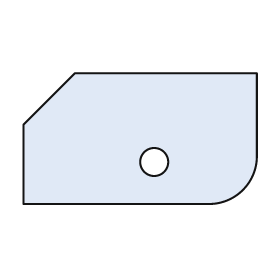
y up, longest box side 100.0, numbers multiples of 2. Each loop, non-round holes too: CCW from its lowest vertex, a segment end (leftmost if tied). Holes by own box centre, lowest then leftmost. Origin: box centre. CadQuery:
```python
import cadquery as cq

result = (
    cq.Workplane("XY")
    .moveTo(-50.0, -28.0)
    .lineTo(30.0, -28.0)
    .threePointArc((44.0, -22.0), (50.0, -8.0))
    .lineTo(50.0, 28.0)
    .lineTo(-28.0, 28.0)
    .lineTo(-50.0, 6.0)
    .close()
    .moveTo(6.0, -10.0)
    .circle(6.0)
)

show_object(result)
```